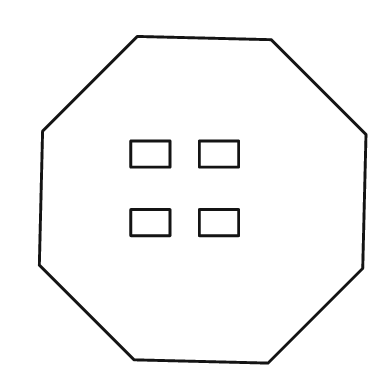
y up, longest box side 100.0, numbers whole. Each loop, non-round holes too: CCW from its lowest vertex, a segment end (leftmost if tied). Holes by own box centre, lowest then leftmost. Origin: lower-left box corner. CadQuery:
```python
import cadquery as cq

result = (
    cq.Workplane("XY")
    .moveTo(70.0, 0.0)
    .lineTo(99.0, 29.0)
    .lineTo(100.0, 70.0)
    .lineTo(71.0, 99.0)
    .lineTo(30.0, 100.0)
    .lineTo(1.0, 71.0)
    .lineTo(0.0, 30.0)
    .lineTo(29.0, 1.0)
    .close()
    .moveTo(28.0, 39.0)
    .lineTo(40.0, 39.0)
    .lineTo(40.0, 47.0)
    .lineTo(28.0, 47.0)
    .close()
    .moveTo(49.0, 39.0)
    .lineTo(61.0, 39.0)
    .lineTo(61.0, 47.0)
    .lineTo(49.0, 47.0)
    .close()
    .moveTo(28.0, 60.0)
    .lineTo(40.0, 60.0)
    .lineTo(40.0, 68.0)
    .lineTo(28.0, 68.0)
    .close()
    .moveTo(49.0, 60.0)
    .lineTo(61.0, 60.0)
    .lineTo(61.0, 68.0)
    .lineTo(49.0, 68.0)
    .close()
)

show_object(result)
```